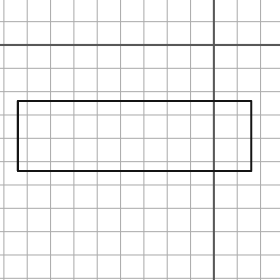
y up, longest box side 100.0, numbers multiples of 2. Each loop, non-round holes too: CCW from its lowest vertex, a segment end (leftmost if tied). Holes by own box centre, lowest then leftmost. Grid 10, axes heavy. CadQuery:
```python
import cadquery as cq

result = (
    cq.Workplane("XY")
    .moveTo(-84.0, -54.0)
    .lineTo(16.0, -54.0)
    .lineTo(16.0, -24.0)
    .lineTo(-84.0, -24.0)
    .close()
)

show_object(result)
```